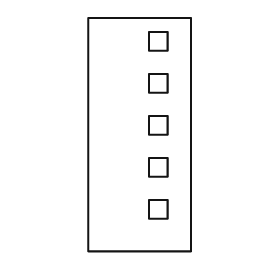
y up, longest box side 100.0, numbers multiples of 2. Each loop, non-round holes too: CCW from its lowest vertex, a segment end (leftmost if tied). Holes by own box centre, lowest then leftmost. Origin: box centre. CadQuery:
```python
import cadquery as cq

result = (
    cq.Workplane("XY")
    .moveTo(-22.0, -50.0)
    .lineTo(22.0, -50.0)
    .lineTo(22.0, 50.0)
    .lineTo(-22.0, 50.0)
    .close()
    .moveTo(4.0, -36.0)
    .lineTo(12.0, -36.0)
    .lineTo(12.0, -28.0)
    .lineTo(4.0, -28.0)
    .close()
    .moveTo(4.0, -18.0)
    .lineTo(12.0, -18.0)
    .lineTo(12.0, -10.0)
    .lineTo(4.0, -10.0)
    .close()
    .moveTo(4.0, 0.0)
    .lineTo(12.0, 0.0)
    .lineTo(12.0, 8.0)
    .lineTo(4.0, 8.0)
    .close()
    .moveTo(4.0, 18.0)
    .lineTo(12.0, 18.0)
    .lineTo(12.0, 26.0)
    .lineTo(4.0, 26.0)
    .close()
    .moveTo(4.0, 36.0)
    .lineTo(12.0, 36.0)
    .lineTo(12.0, 44.0)
    .lineTo(4.0, 44.0)
    .close()
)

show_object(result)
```